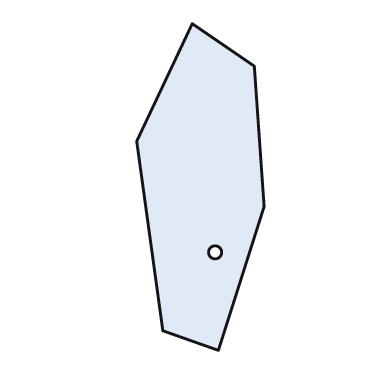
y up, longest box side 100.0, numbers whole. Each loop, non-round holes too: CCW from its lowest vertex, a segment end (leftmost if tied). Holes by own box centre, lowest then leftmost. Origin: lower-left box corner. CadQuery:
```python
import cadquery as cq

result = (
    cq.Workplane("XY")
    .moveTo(25.0, 0.0)
    .lineTo(39.0, 44.0)
    .lineTo(36.0, 87.0)
    .lineTo(17.0, 100.0)
    .lineTo(0.0, 64.0)
    .lineTo(8.0, 6.0)
    .close()
    .moveTo(24.0, 30.0)
    .circle(2.0)
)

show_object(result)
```